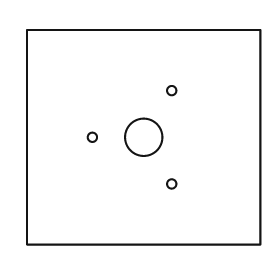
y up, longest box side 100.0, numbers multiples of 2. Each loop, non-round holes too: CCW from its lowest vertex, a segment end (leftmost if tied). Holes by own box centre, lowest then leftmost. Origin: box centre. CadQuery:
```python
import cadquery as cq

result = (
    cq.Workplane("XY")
    .moveTo(-50.0, -46.0)
    .lineTo(50.0, -46.0)
    .lineTo(50.0, 46.0)
    .lineTo(-50.0, 46.0)
    .close()
    .moveTo(12.0, -20.0)
    .circle(2.0)
    .moveTo(-22.0, 0.0)
    .circle(2.0)
    .moveTo(0.0, 0.0)
    .circle(8.0)
    .moveTo(12.0, 20.0)
    .circle(2.0)
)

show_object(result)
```